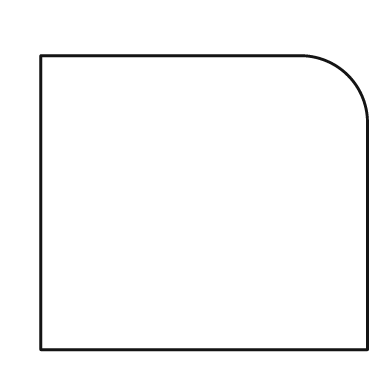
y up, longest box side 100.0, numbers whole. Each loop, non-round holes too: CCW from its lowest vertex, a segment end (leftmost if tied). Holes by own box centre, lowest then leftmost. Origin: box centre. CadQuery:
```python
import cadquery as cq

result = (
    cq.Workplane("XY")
    .moveTo(-50.0, -45.0)
    .lineTo(50.0, -45.0)
    .lineTo(50.0, 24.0)
    .threePointArc((44.0, 39.0), (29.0, 45.0))
    .lineTo(-50.0, 45.0)
    .close()
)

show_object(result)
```